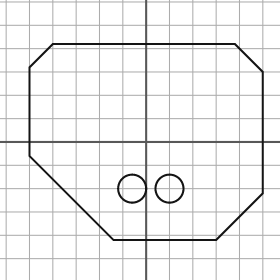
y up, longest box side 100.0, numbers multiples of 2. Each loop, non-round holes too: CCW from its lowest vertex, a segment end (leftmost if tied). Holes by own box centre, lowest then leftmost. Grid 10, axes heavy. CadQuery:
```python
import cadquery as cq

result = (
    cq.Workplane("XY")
    .moveTo(-14.0, -42.0)
    .lineTo(30.0, -42.0)
    .lineTo(50.0, -22.0)
    .lineTo(50.0, 30.0)
    .lineTo(38.0, 42.0)
    .lineTo(-40.0, 42.0)
    .lineTo(-50.0, 32.0)
    .lineTo(-50.0, -6.0)
    .close()
    .moveTo(-6.0, -20.0)
    .circle(6.0)
    .moveTo(10.0, -20.0)
    .circle(6.0)
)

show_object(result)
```